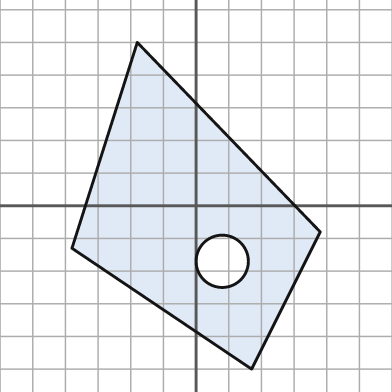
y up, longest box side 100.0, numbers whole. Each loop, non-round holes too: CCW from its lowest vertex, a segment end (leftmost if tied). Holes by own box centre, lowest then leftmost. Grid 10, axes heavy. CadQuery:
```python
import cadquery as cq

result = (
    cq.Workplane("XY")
    .moveTo(17.0, -50.0)
    .lineTo(38.0, -8.0)
    .lineTo(-18.0, 50.0)
    .lineTo(-38.0, -13.0)
    .close()
    .moveTo(8.0, -17.0)
    .circle(8.0)
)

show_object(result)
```